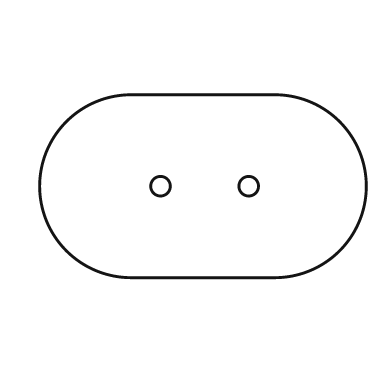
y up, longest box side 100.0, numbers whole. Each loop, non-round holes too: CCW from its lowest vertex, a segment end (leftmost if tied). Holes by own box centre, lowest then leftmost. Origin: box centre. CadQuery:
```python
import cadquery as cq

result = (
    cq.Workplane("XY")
    .moveTo(-22.0, -28.0)
    .lineTo(22.0, -28.0)
    .threePointArc((50.0, 0.0), (22.0, 28.0))
    .lineTo(-22.0, 28.0)
    .threePointArc((-50.0, 0.0), (-22.0, -28.0))
    .close()
    .moveTo(-13.0, 0.0)
    .circle(3.0)
    .moveTo(14.0, 0.0)
    .circle(3.0)
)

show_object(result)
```